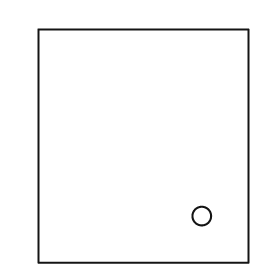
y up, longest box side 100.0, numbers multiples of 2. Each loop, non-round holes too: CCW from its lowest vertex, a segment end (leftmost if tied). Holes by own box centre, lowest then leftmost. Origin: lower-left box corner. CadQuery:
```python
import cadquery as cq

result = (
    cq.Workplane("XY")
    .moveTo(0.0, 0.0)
    .lineTo(90.0, 0.0)
    .lineTo(90.0, 100.0)
    .lineTo(0.0, 100.0)
    .close()
    .moveTo(70.0, 20.0)
    .circle(4.0)
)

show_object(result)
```